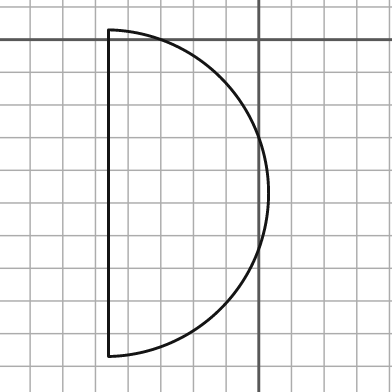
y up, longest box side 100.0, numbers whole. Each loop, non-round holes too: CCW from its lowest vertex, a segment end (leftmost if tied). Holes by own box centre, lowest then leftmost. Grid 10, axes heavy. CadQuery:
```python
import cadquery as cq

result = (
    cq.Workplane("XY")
    .moveTo(-46.0, -97.0)
    .threePointArc((3.0, -47.0), (-46.0, 3.0))
    .close()
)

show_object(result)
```